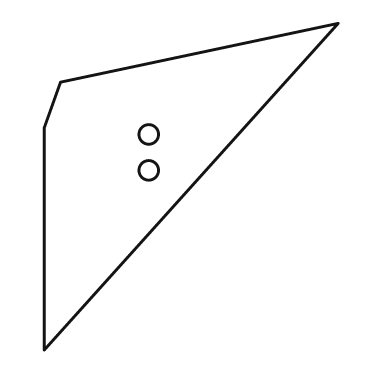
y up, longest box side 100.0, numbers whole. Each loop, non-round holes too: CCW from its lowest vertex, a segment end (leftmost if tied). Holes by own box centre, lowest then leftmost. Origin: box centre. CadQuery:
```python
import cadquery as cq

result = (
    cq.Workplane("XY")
    .moveTo(-45.0, -50.0)
    .lineTo(45.0, 50.0)
    .lineTo(-40.0, 32.0)
    .lineTo(-45.0, 18.0)
    .close()
    .moveTo(-13.0, 5.0)
    .circle(3.0)
    .moveTo(-13.0, 16.0)
    .circle(3.0)
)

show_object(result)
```